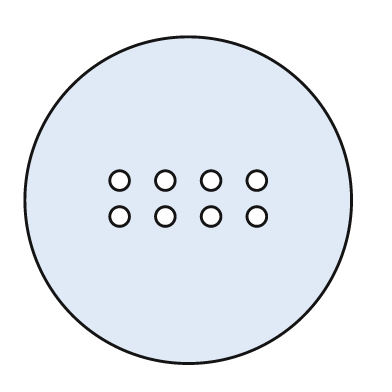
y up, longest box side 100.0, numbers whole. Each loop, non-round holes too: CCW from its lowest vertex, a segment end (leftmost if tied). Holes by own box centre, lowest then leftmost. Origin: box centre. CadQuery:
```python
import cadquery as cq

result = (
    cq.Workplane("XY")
    .moveTo(0.0, 0.0)
    .circle(50.0)
    .moveTo(-21.0, -5.0)
    .circle(3.0)
    .moveTo(-7.0, -5.0)
    .circle(3.0)
    .moveTo(7.0, -5.0)
    .circle(3.0)
    .moveTo(21.0, -5.0)
    .circle(3.0)
    .moveTo(-21.0, 6.0)
    .circle(3.0)
    .moveTo(-7.0, 6.0)
    .circle(3.0)
    .moveTo(7.0, 6.0)
    .circle(3.0)
    .moveTo(21.0, 6.0)
    .circle(3.0)
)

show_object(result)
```